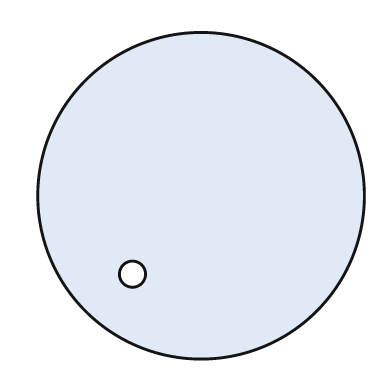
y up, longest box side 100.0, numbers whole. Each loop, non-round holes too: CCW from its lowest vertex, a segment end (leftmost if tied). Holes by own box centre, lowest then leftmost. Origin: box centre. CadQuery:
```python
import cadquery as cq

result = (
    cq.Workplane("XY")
    .moveTo(0.0, 0.0)
    .circle(50.0)
    .moveTo(-21.0, -24.0)
    .circle(4.0)
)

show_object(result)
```